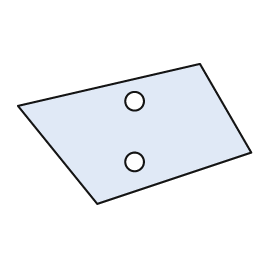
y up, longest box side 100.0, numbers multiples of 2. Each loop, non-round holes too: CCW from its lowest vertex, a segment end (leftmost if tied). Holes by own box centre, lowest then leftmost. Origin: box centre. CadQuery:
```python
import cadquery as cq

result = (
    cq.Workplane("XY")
    .moveTo(-16.0, -30.0)
    .lineTo(50.0, -8.0)
    .lineTo(28.0, 30.0)
    .lineTo(-50.0, 12.0)
    .close()
    .moveTo(0.0, -12.0)
    .circle(4.0)
    .moveTo(0.0, 14.0)
    .circle(4.0)
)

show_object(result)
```